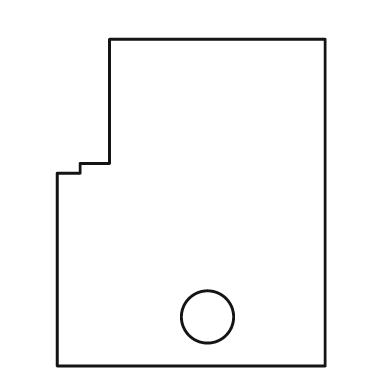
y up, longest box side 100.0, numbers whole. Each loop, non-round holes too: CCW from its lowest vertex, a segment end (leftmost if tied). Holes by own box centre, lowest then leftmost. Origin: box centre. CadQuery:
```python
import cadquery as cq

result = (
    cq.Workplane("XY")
    .moveTo(-41.0, -50.0)
    .lineTo(41.0, -50.0)
    .lineTo(41.0, 50.0)
    .lineTo(-25.0, 50.0)
    .lineTo(-25.0, 12.0)
    .lineTo(-34.0, 12.0)
    .lineTo(-34.0, 9.0)
    .lineTo(-41.0, 9.0)
    .close()
    .moveTo(5.0, -35.0)
    .circle(8.0)
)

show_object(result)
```